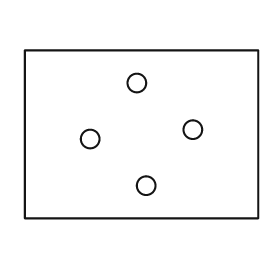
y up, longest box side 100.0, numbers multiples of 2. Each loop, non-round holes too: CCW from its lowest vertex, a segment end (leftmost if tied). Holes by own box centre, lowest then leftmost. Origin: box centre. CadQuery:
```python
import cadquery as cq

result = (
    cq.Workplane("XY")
    .moveTo(-50.0, -36.0)
    .lineTo(50.0, -36.0)
    .lineTo(50.0, 36.0)
    .lineTo(-50.0, 36.0)
    .close()
    .moveTo(2.0, -22.0)
    .circle(4.0)
    .moveTo(-22.0, -2.0)
    .circle(4.0)
    .moveTo(22.0, 2.0)
    .circle(4.0)
    .moveTo(-2.0, 22.0)
    .circle(4.0)
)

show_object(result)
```